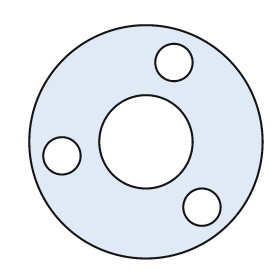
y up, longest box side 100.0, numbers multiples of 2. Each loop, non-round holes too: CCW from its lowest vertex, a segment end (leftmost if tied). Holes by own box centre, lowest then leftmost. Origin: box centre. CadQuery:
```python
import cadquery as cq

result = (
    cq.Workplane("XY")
    .moveTo(0.0, 0.0)
    .circle(50.0)
    .moveTo(24.0, -28.0)
    .circle(8.0)
    .moveTo(-36.0, -6.0)
    .circle(8.0)
    .moveTo(0.0, 0.0)
    .circle(20.0)
    .moveTo(12.0, 34.0)
    .circle(8.0)
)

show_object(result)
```